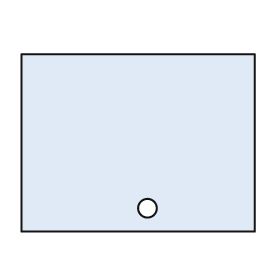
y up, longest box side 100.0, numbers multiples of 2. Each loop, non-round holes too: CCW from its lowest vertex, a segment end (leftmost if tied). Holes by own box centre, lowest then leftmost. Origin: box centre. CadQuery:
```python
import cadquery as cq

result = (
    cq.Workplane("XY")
    .moveTo(-50.0, -38.0)
    .lineTo(50.0, -38.0)
    .lineTo(50.0, 38.0)
    .lineTo(-50.0, 38.0)
    .close()
    .moveTo(4.0, -28.0)
    .circle(4.0)
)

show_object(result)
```